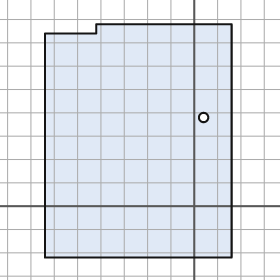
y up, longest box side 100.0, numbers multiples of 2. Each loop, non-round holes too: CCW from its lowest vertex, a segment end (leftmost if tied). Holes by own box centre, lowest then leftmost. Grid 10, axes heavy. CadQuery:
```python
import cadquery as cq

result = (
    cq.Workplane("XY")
    .moveTo(-64.0, -22.0)
    .lineTo(16.0, -22.0)
    .lineTo(16.0, 78.0)
    .lineTo(-42.0, 78.0)
    .lineTo(-42.0, 74.0)
    .lineTo(-64.0, 74.0)
    .close()
    .moveTo(4.0, 38.0)
    .circle(2.0)
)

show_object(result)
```